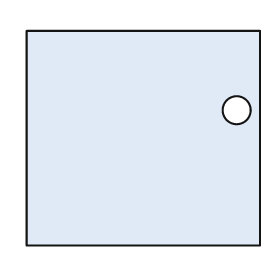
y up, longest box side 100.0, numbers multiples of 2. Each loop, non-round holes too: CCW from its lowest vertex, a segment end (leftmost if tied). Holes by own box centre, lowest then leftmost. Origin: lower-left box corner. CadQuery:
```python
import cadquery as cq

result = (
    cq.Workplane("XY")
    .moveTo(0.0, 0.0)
    .lineTo(100.0, 0.0)
    .lineTo(100.0, 92.0)
    .lineTo(0.0, 92.0)
    .close()
    .moveTo(90.0, 58.0)
    .circle(6.0)
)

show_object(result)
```